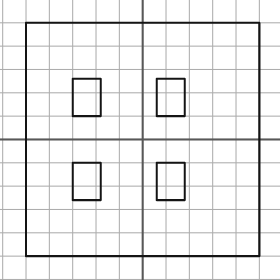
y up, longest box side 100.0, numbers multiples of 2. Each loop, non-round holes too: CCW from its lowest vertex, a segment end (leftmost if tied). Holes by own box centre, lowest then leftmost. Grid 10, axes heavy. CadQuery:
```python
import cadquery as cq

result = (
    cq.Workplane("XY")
    .moveTo(-50.0, -50.0)
    .lineTo(50.0, -50.0)
    .lineTo(50.0, 50.0)
    .lineTo(-50.0, 50.0)
    .close()
    .moveTo(-30.0, -26.0)
    .lineTo(-18.0, -26.0)
    .lineTo(-18.0, -10.0)
    .lineTo(-30.0, -10.0)
    .close()
    .moveTo(6.0, -26.0)
    .lineTo(18.0, -26.0)
    .lineTo(18.0, -10.0)
    .lineTo(6.0, -10.0)
    .close()
    .moveTo(-30.0, 10.0)
    .lineTo(-18.0, 10.0)
    .lineTo(-18.0, 26.0)
    .lineTo(-30.0, 26.0)
    .close()
    .moveTo(6.0, 10.0)
    .lineTo(18.0, 10.0)
    .lineTo(18.0, 26.0)
    .lineTo(6.0, 26.0)
    .close()
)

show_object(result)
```